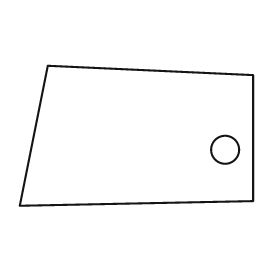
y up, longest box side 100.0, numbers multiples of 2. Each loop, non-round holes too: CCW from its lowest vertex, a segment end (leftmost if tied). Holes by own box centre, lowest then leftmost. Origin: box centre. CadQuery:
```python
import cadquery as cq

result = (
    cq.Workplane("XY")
    .moveTo(-50.0, -30.0)
    .lineTo(50.0, -28.0)
    .lineTo(50.0, 26.0)
    .lineTo(-38.0, 30.0)
    .close()
    .moveTo(38.0, -6.0)
    .circle(6.0)
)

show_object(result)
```